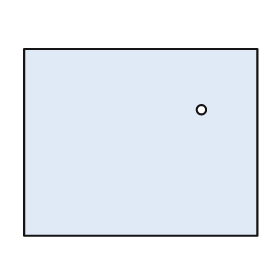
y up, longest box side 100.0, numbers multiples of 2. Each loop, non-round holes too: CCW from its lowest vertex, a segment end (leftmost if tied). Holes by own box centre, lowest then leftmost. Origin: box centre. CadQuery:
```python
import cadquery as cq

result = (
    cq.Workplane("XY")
    .moveTo(-50.0, -40.0)
    .lineTo(50.0, -40.0)
    .lineTo(50.0, 40.0)
    .lineTo(-50.0, 40.0)
    .close()
    .moveTo(26.0, 14.0)
    .circle(2.0)
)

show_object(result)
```